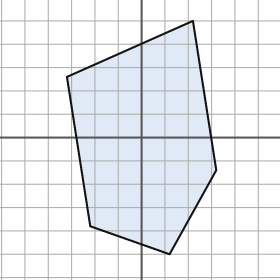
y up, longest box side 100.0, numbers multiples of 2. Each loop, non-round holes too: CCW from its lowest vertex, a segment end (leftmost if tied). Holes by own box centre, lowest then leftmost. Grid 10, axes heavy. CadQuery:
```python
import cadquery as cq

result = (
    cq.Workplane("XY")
    .moveTo(12.0, -50.0)
    .lineTo(32.0, -14.0)
    .lineTo(22.0, 50.0)
    .lineTo(-32.0, 26.0)
    .lineTo(-22.0, -38.0)
    .close()
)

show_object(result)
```